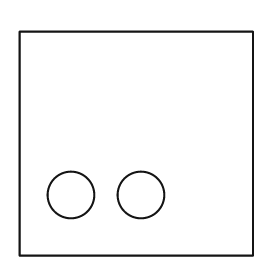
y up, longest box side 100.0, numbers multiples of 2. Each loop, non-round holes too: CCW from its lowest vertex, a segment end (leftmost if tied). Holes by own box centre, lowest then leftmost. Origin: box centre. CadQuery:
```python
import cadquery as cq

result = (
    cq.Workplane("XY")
    .moveTo(-50.0, -48.0)
    .lineTo(50.0, -48.0)
    .lineTo(50.0, 48.0)
    .lineTo(-50.0, 48.0)
    .close()
    .moveTo(-28.0, -22.0)
    .circle(10.0)
    .moveTo(2.0, -22.0)
    .circle(10.0)
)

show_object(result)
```